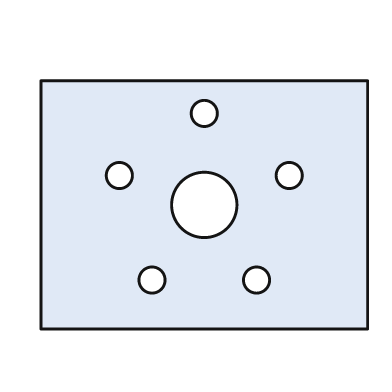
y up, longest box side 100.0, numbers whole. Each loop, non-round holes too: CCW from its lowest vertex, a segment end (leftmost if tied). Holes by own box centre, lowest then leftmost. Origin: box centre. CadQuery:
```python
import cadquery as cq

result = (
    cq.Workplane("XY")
    .moveTo(-50.0, -38.0)
    .lineTo(50.0, -38.0)
    .lineTo(50.0, 38.0)
    .lineTo(-50.0, 38.0)
    .close()
    .moveTo(-16.0, -23.0)
    .circle(4.0)
    .moveTo(16.0, -23.0)
    .circle(4.0)
    .moveTo(0.0, 0.0)
    .circle(10.0)
    .moveTo(-26.0, 9.0)
    .circle(4.0)
    .moveTo(26.0, 9.0)
    .circle(4.0)
    .moveTo(0.0, 28.0)
    .circle(4.0)
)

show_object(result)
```